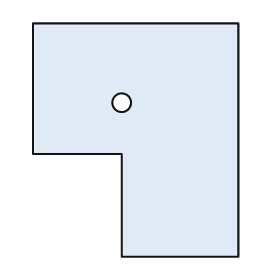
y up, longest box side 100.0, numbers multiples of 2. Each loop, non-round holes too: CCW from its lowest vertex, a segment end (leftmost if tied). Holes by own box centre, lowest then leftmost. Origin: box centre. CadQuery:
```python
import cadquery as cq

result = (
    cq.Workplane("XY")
    .moveTo(-6.0, -50.0)
    .lineTo(44.0, -50.0)
    .lineTo(44.0, 50.0)
    .lineTo(-44.0, 50.0)
    .lineTo(-44.0, -6.0)
    .lineTo(-6.0, -6.0)
    .close()
    .moveTo(-6.0, 16.0)
    .circle(4.0)
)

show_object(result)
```